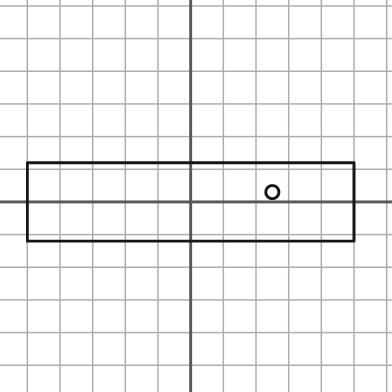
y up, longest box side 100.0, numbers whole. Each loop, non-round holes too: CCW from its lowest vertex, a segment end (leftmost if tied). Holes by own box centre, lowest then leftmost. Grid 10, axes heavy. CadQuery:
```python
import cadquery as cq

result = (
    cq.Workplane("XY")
    .moveTo(-50.0, -12.0)
    .lineTo(50.0, -12.0)
    .lineTo(50.0, 12.0)
    .lineTo(-50.0, 12.0)
    .close()
    .moveTo(25.0, 3.0)
    .circle(2.0)
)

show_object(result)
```